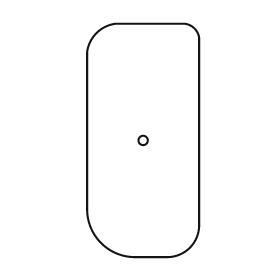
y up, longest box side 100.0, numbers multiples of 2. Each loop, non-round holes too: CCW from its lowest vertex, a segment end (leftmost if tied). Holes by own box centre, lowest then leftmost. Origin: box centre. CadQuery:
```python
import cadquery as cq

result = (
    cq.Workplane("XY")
    .moveTo(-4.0, -50.0)
    .lineTo(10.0, -50.0)
    .threePointArc((20.0, -46.0), (24.0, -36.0))
    .lineTo(24.0, 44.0)
    .threePointArc((22.0, 48.0), (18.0, 50.0))
    .lineTo(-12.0, 50.0)
    .threePointArc((-20.0, 46.0), (-24.0, 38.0))
    .lineTo(-24.0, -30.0)
    .threePointArc((-18.0, -44.0), (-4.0, -50.0))
    .close()
    .moveTo(0.0, 0.0)
    .circle(2.0)
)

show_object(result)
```